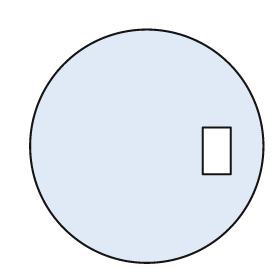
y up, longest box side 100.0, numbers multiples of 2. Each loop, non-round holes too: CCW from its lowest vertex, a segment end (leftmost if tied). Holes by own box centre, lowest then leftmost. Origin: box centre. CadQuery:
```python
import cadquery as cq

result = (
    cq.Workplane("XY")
    .moveTo(0.0, 0.0)
    .circle(50.0)
    .moveTo(24.0, -12.0)
    .lineTo(36.0, -12.0)
    .lineTo(36.0, 8.0)
    .lineTo(24.0, 8.0)
    .close()
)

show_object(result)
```